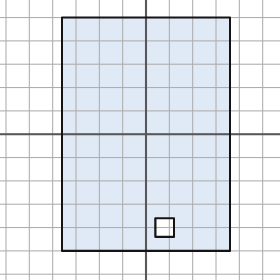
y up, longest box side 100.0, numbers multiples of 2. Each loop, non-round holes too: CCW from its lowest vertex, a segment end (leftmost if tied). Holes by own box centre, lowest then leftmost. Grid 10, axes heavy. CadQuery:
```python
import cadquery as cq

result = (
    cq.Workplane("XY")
    .moveTo(-36.0, -50.0)
    .lineTo(36.0, -50.0)
    .lineTo(36.0, 50.0)
    .lineTo(-36.0, 50.0)
    .close()
    .moveTo(4.0, -44.0)
    .lineTo(12.0, -44.0)
    .lineTo(12.0, -36.0)
    .lineTo(4.0, -36.0)
    .close()
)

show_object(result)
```